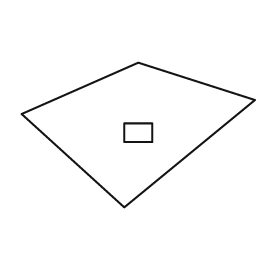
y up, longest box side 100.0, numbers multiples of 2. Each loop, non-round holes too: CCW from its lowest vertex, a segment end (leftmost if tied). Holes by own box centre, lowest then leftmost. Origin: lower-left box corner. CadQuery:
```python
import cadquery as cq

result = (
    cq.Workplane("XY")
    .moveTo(44.0, 0.0)
    .lineTo(100.0, 46.0)
    .lineTo(50.0, 62.0)
    .lineTo(0.0, 40.0)
    .close()
    .moveTo(44.0, 28.0)
    .lineTo(56.0, 28.0)
    .lineTo(56.0, 36.0)
    .lineTo(44.0, 36.0)
    .close()
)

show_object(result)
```